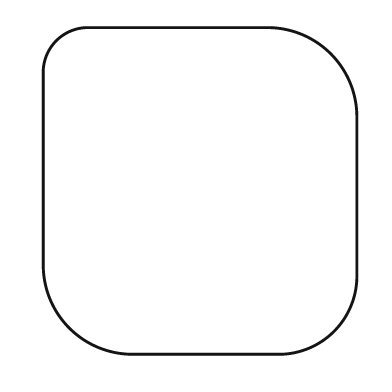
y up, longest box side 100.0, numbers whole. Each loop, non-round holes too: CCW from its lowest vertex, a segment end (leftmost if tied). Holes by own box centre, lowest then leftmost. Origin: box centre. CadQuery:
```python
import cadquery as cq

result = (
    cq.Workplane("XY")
    .moveTo(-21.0, -50.0)
    .lineTo(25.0, -50.0)
    .threePointArc((41.0, -43.0), (48.0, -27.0))
    .lineTo(48.0, 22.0)
    .threePointArc((40.0, 42.0), (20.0, 50.0))
    .lineTo(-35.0, 50.0)
    .threePointArc((-44.0, 46.0), (-48.0, 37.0))
    .lineTo(-48.0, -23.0)
    .threePointArc((-40.0, -42.0), (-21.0, -50.0))
    .close()
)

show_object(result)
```